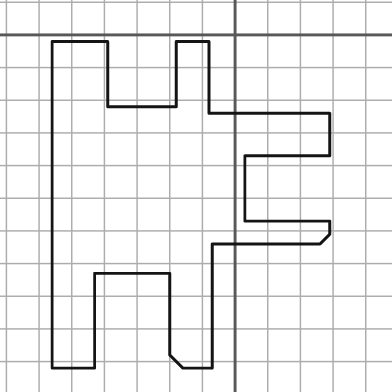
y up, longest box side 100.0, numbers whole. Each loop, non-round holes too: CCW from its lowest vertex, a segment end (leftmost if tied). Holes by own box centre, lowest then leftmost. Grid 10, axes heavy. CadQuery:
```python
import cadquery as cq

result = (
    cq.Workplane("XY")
    .moveTo(-56.0, -102.0)
    .lineTo(-43.0, -102.0)
    .lineTo(-43.0, -73.0)
    .lineTo(-20.0, -73.0)
    .lineTo(-20.0, -98.0)
    .lineTo(-16.0, -102.0)
    .lineTo(-7.0, -102.0)
    .lineTo(-7.0, -64.0)
    .lineTo(26.0, -64.0)
    .lineTo(29.0, -61.0)
    .lineTo(29.0, -57.0)
    .lineTo(3.0, -57.0)
    .lineTo(3.0, -37.0)
    .lineTo(29.0, -37.0)
    .lineTo(29.0, -24.0)
    .lineTo(-8.0, -24.0)
    .lineTo(-8.0, -2.0)
    .lineTo(-18.0, -2.0)
    .lineTo(-18.0, -22.0)
    .lineTo(-39.0, -22.0)
    .lineTo(-39.0, -2.0)
    .lineTo(-56.0, -2.0)
    .close()
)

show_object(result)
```